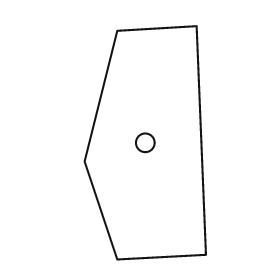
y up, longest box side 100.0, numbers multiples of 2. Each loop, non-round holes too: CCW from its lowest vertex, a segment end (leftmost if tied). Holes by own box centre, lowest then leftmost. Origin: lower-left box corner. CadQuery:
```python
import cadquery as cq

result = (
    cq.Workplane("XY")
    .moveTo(14.0, 0.0)
    .lineTo(52.0, 2.0)
    .lineTo(48.0, 100.0)
    .lineTo(14.0, 98.0)
    .lineTo(0.0, 42.0)
    .close()
    .moveTo(26.0, 50.0)
    .circle(4.0)
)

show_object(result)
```